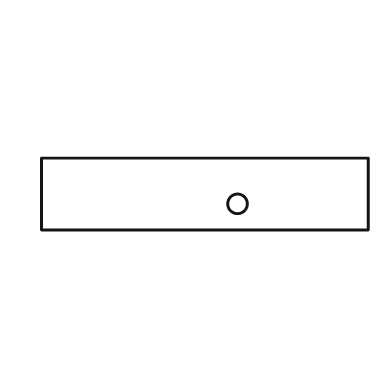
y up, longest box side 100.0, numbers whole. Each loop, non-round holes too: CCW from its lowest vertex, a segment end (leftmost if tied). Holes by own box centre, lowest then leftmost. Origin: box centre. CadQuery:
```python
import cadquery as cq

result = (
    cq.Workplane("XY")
    .moveTo(-50.0, -11.0)
    .lineTo(50.0, -11.0)
    .lineTo(50.0, 11.0)
    .lineTo(-50.0, 11.0)
    .close()
    .moveTo(10.0, -3.0)
    .circle(3.0)
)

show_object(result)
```